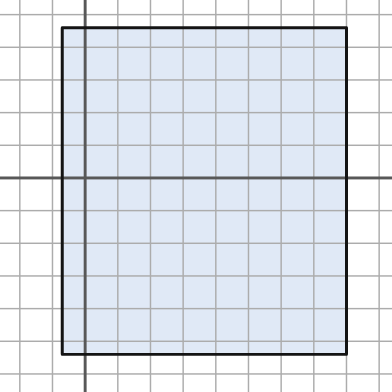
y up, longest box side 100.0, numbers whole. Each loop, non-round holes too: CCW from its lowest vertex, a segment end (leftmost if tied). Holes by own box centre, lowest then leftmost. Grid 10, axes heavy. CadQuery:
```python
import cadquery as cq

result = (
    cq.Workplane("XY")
    .moveTo(-7.0, -54.0)
    .lineTo(80.0, -54.0)
    .lineTo(80.0, 46.0)
    .lineTo(-7.0, 46.0)
    .close()
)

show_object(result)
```